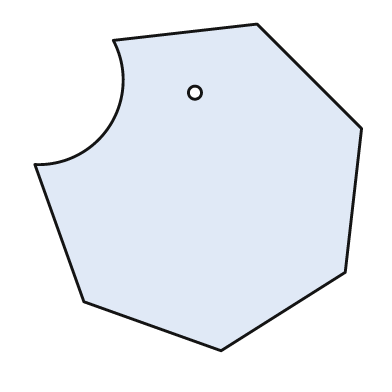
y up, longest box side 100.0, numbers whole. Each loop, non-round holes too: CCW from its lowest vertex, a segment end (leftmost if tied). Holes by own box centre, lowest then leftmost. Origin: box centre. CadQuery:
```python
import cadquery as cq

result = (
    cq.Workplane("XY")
    .moveTo(7.0, -50.0)
    .lineTo(45.0, -26.0)
    .lineTo(50.0, 18.0)
    .lineTo(18.0, 50.0)
    .lineTo(-26.0, 45.0)
    .threePointArc((-27.0, 19.0), (-50.0, 7.0))
    .lineTo(-35.0, -35.0)
    .close()
    .moveTo(-1.0, 29.0)
    .circle(2.0)
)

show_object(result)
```